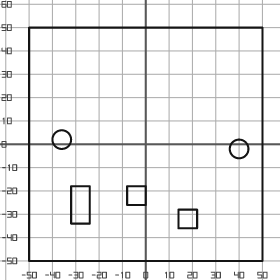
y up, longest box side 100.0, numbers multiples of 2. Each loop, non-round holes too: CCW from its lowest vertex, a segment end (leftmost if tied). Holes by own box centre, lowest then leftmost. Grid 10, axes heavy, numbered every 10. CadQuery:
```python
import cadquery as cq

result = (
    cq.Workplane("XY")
    .moveTo(-50.0, -50.0)
    .lineTo(50.0, -50.0)
    .lineTo(50.0, 50.0)
    .lineTo(-50.0, 50.0)
    .close()
    .moveTo(14.0, -36.0)
    .lineTo(22.0, -36.0)
    .lineTo(22.0, -28.0)
    .lineTo(14.0, -28.0)
    .close()
    .moveTo(-32.0, -34.0)
    .lineTo(-24.0, -34.0)
    .lineTo(-24.0, -18.0)
    .lineTo(-32.0, -18.0)
    .close()
    .moveTo(-8.0, -26.0)
    .lineTo(0.0, -26.0)
    .lineTo(0.0, -18.0)
    .lineTo(-8.0, -18.0)
    .close()
    .moveTo(40.0, -2.0)
    .circle(4.0)
    .moveTo(-36.0, 2.0)
    .circle(4.0)
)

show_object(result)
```